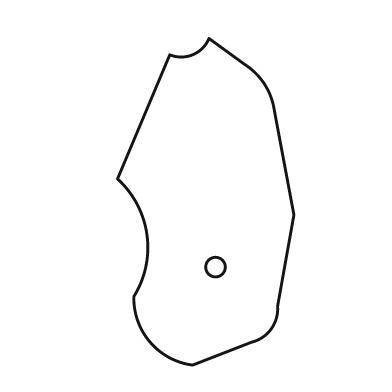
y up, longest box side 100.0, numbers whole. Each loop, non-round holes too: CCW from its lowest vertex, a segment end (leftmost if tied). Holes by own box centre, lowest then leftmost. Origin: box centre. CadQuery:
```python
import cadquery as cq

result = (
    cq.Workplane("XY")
    .moveTo(-4.0, -50.0)
    .lineTo(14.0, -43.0)
    .threePointArc((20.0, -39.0), (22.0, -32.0))
    .lineTo(27.0, -4.0)
    .lineTo(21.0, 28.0)
    .threePointArc((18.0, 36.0), (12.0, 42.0))
    .lineTo(1.0, 50.0)
    .threePointArc((-4.0, 45.0), (-11.0, 45.0))
    .lineTo(-27.0, 7.0)
    .threePointArc((-18.0, -10.0), (-22.0, -29.0))
    .threePointArc((-17.0, -43.0), (-4.0, -50.0))
    .close()
    .moveTo(3.0, -20.0)
    .circle(3.0)
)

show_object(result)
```